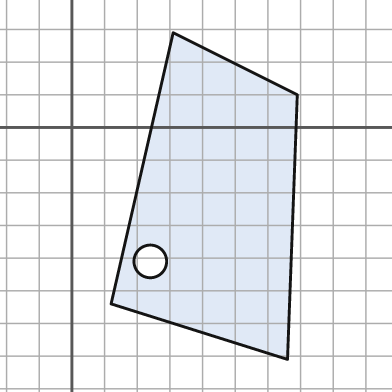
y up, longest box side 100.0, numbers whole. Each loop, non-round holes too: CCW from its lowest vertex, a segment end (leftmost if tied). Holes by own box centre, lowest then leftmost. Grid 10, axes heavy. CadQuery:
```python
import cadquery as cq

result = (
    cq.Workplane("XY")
    .moveTo(66.0, -71.0)
    .lineTo(69.0, 10.0)
    .lineTo(31.0, 29.0)
    .lineTo(12.0, -54.0)
    .close()
    .moveTo(24.0, -41.0)
    .circle(5.0)
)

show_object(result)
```